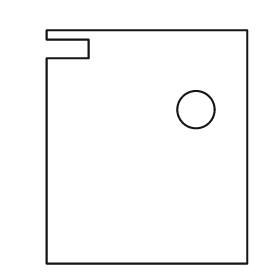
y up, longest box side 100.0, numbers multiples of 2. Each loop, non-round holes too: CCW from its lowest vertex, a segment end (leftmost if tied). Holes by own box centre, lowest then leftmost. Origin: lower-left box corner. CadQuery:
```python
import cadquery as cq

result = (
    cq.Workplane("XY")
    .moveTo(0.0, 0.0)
    .lineTo(86.0, 0.0)
    .lineTo(86.0, 100.0)
    .lineTo(0.0, 100.0)
    .lineTo(0.0, 96.0)
    .lineTo(18.0, 96.0)
    .lineTo(18.0, 88.0)
    .lineTo(0.0, 88.0)
    .close()
    .moveTo(64.0, 66.0)
    .circle(8.0)
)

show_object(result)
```